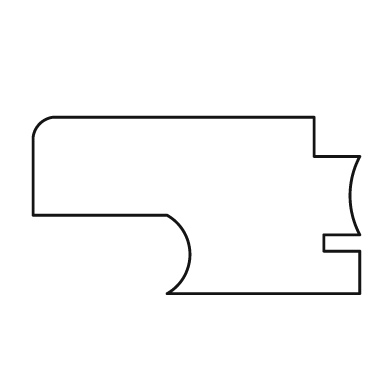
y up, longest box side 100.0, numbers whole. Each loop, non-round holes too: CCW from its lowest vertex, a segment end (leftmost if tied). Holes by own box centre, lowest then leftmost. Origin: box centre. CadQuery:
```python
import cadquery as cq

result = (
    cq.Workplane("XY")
    .moveTo(-9.0, -27.0)
    .lineTo(50.0, -27.0)
    .lineTo(50.0, -14.0)
    .lineTo(39.0, -14.0)
    .lineTo(39.0, -9.0)
    .lineTo(50.0, -9.0)
    .threePointArc((47.0, 3.0), (50.0, 15.0))
    .lineTo(36.0, 15.0)
    .lineTo(36.0, 27.0)
    .lineTo(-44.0, 27.0)
    .threePointArc((-48.0, 25.0), (-50.0, 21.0))
    .lineTo(-50.0, -3.0)
    .lineTo(-9.0, -3.0)
    .threePointArc((-2.0, -15.0), (-9.0, -27.0))
    .close()
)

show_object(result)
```